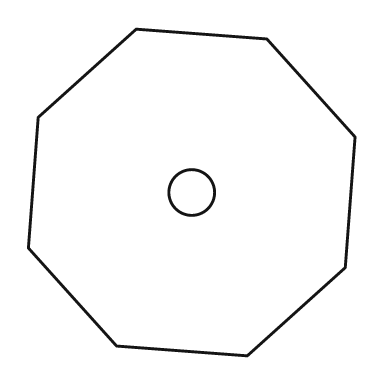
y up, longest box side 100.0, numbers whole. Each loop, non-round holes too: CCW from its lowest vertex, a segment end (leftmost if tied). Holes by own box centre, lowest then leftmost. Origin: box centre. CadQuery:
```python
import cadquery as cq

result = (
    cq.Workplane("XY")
    .moveTo(17.0, -50.0)
    .lineTo(47.0, -23.0)
    .lineTo(50.0, 17.0)
    .lineTo(23.0, 47.0)
    .lineTo(-17.0, 50.0)
    .lineTo(-47.0, 23.0)
    .lineTo(-50.0, -17.0)
    .lineTo(-23.0, -47.0)
    .close()
    .moveTo(0.0, 0.0)
    .circle(7.0)
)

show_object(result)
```